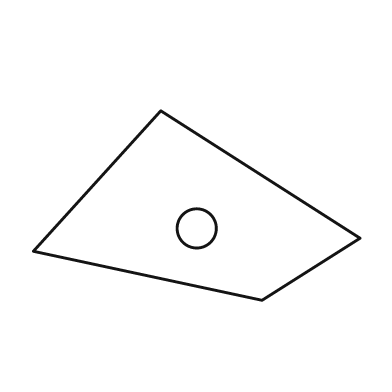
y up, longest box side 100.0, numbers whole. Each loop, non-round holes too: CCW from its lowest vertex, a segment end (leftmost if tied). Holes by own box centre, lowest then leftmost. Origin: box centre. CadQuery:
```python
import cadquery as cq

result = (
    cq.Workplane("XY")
    .moveTo(20.0, -29.0)
    .lineTo(50.0, -10.0)
    .lineTo(-11.0, 29.0)
    .lineTo(-50.0, -14.0)
    .close()
    .moveTo(0.0, -7.0)
    .circle(6.0)
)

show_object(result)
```